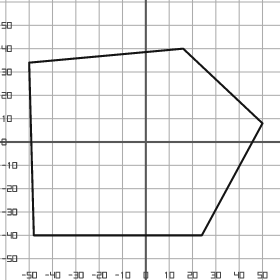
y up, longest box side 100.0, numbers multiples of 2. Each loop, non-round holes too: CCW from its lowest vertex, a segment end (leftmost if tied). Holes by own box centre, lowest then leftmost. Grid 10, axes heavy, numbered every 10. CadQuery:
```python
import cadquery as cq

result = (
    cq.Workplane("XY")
    .moveTo(-48.0, -40.0)
    .lineTo(24.0, -40.0)
    .lineTo(50.0, 8.0)
    .lineTo(16.0, 40.0)
    .lineTo(-50.0, 34.0)
    .close()
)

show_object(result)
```